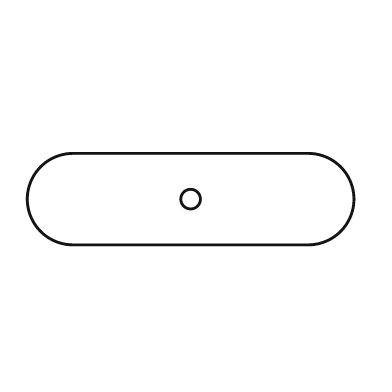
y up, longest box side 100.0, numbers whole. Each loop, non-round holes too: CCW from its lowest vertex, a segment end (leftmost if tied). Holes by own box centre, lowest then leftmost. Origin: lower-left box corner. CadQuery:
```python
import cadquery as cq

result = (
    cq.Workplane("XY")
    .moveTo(14.0, 0.0)
    .lineTo(86.0, 0.0)
    .threePointArc((100.0, 14.0), (86.0, 28.0))
    .lineTo(14.0, 28.0)
    .threePointArc((0.0, 14.0), (14.0, 0.0))
    .close()
    .moveTo(50.0, 14.0)
    .circle(3.0)
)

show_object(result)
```